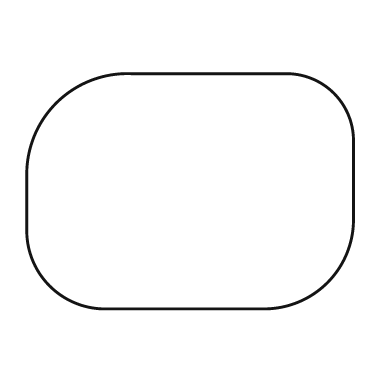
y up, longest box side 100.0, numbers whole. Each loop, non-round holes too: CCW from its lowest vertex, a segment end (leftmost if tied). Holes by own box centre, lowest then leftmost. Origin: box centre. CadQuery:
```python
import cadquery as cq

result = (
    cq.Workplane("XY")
    .moveTo(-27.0, -36.0)
    .lineTo(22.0, -36.0)
    .threePointArc((42.0, -28.0), (50.0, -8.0))
    .lineTo(50.0, 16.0)
    .threePointArc((44.0, 30.0), (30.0, 36.0))
    .lineTo(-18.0, 36.0)
    .threePointArc((-41.0, 27.0), (-50.0, 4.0))
    .lineTo(-50.0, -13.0)
    .threePointArc((-43.0, -29.0), (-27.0, -36.0))
    .close()
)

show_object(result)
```